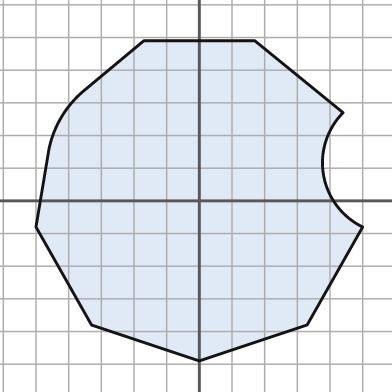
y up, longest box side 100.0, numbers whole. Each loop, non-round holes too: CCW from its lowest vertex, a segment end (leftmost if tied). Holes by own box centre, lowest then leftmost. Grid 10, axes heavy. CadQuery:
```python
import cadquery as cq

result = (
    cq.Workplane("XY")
    .moveTo(0.0, -49.0)
    .lineTo(33.0, -38.0)
    .lineTo(50.0, -8.0)
    .threePointArc((38.0, 8.0), (44.0, 27.0))
    .lineTo(17.0, 49.0)
    .lineTo(-17.0, 49.0)
    .lineTo(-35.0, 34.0)
    .threePointArc((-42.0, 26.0), (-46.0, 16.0))
    .lineTo(-50.0, -8.0)
    .lineTo(-33.0, -38.0)
    .close()
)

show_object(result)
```